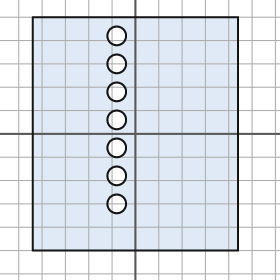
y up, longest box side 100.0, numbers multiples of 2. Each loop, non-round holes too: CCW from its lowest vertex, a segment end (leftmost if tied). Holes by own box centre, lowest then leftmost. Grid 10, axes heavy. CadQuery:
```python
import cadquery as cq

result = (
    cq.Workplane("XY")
    .moveTo(-44.0, -50.0)
    .lineTo(44.0, -50.0)
    .lineTo(44.0, 50.0)
    .lineTo(-44.0, 50.0)
    .close()
    .moveTo(-8.0, -30.0)
    .circle(4.0)
    .moveTo(-8.0, -18.0)
    .circle(4.0)
    .moveTo(-8.0, -6.0)
    .circle(4.0)
    .moveTo(-8.0, 6.0)
    .circle(4.0)
    .moveTo(-8.0, 18.0)
    .circle(4.0)
    .moveTo(-8.0, 30.0)
    .circle(4.0)
    .moveTo(-8.0, 42.0)
    .circle(4.0)
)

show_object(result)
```